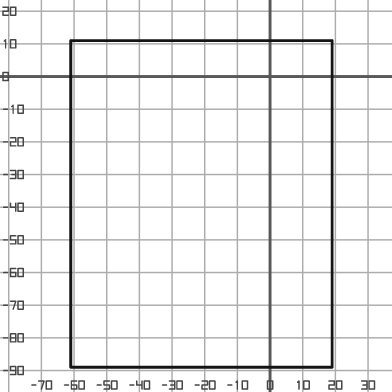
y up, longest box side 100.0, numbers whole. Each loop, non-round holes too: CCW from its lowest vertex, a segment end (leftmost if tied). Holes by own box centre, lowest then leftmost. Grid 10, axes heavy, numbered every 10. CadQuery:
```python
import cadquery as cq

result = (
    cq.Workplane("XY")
    .moveTo(-61.0, -89.0)
    .lineTo(19.0, -89.0)
    .lineTo(19.0, 11.0)
    .lineTo(-61.0, 11.0)
    .close()
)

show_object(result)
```